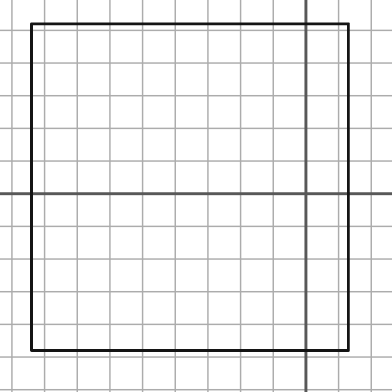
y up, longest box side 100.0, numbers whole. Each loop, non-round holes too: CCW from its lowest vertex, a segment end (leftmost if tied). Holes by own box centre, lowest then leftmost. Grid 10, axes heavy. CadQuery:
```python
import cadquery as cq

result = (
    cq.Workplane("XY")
    .moveTo(-84.0, -48.0)
    .lineTo(13.0, -48.0)
    .lineTo(13.0, 52.0)
    .lineTo(-84.0, 52.0)
    .close()
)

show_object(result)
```